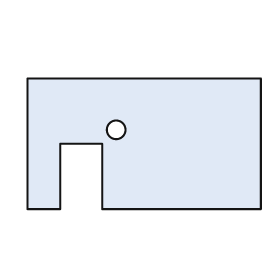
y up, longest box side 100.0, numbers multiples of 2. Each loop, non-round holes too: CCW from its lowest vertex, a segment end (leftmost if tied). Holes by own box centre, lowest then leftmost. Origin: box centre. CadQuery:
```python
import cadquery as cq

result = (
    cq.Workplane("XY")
    .moveTo(-50.0, -28.0)
    .lineTo(-36.0, -28.0)
    .lineTo(-36.0, 0.0)
    .lineTo(-18.0, 0.0)
    .lineTo(-18.0, -28.0)
    .lineTo(50.0, -28.0)
    .lineTo(50.0, 28.0)
    .lineTo(-50.0, 28.0)
    .close()
    .moveTo(-12.0, 6.0)
    .circle(4.0)
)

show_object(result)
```